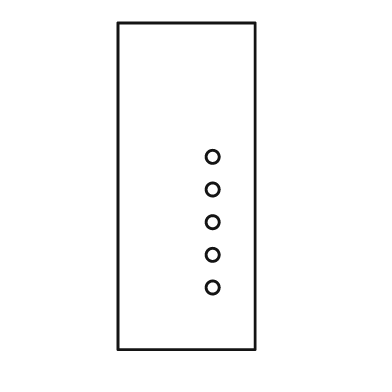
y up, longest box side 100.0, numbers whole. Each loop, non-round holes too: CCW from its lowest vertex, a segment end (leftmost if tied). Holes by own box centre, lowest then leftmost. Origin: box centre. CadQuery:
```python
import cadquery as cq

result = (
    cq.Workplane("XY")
    .moveTo(-21.0, -50.0)
    .lineTo(21.0, -50.0)
    .lineTo(21.0, 50.0)
    .lineTo(-21.0, 50.0)
    .close()
    .moveTo(8.0, -31.0)
    .circle(2.0)
    .moveTo(8.0, -21.0)
    .circle(2.0)
    .moveTo(8.0, -11.0)
    .circle(2.0)
    .moveTo(8.0, -1.0)
    .circle(2.0)
    .moveTo(8.0, 9.0)
    .circle(2.0)
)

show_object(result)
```